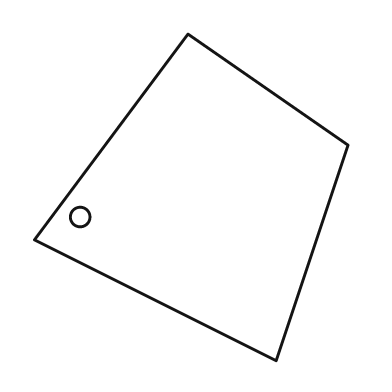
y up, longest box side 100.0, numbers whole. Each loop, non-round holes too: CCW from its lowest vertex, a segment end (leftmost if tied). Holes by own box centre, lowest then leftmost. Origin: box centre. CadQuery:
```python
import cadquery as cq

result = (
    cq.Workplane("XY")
    .moveTo(26.0, -50.0)
    .lineTo(48.0, 16.0)
    .lineTo(-1.0, 50.0)
    .lineTo(-48.0, -13.0)
    .close()
    .moveTo(-34.0, -6.0)
    .circle(3.0)
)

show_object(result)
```